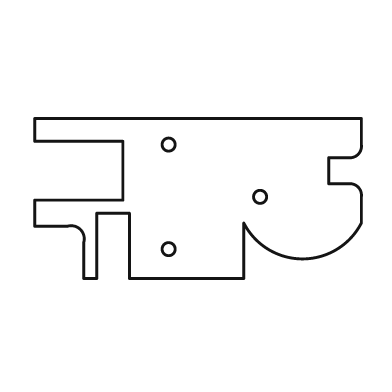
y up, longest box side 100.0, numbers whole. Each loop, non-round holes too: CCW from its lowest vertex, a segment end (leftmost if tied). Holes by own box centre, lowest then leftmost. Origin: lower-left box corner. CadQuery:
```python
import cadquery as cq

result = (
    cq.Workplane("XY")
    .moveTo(15.0, 0.0)
    .lineTo(19.0, 0.0)
    .lineTo(19.0, 20.0)
    .lineTo(29.0, 20.0)
    .lineTo(29.0, 0.0)
    .lineTo(64.0, 0.0)
    .lineTo(64.0, 17.0)
    .threePointArc((82.0, 6.0), (100.0, 17.0))
    .lineTo(100.0, 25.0)
    .threePointArc((99.0, 28.0), (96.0, 29.0))
    .lineTo(90.0, 29.0)
    .lineTo(90.0, 37.0)
    .lineTo(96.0, 37.0)
    .threePointArc((99.0, 38.0), (100.0, 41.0))
    .lineTo(100.0, 49.0)
    .lineTo(0.0, 49.0)
    .lineTo(0.0, 42.0)
    .lineTo(27.0, 42.0)
    .lineTo(27.0, 24.0)
    .lineTo(0.0, 24.0)
    .lineTo(0.0, 16.0)
    .lineTo(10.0, 16.0)
    .threePointArc((14.0, 15.0), (15.0, 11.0))
    .close()
    .moveTo(41.0, 9.0)
    .circle(2.0)
    .moveTo(69.0, 25.0)
    .circle(2.0)
    .moveTo(41.0, 41.0)
    .circle(2.0)
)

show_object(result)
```